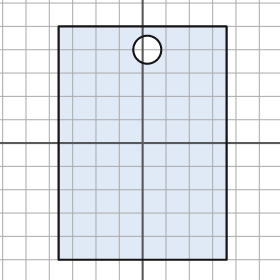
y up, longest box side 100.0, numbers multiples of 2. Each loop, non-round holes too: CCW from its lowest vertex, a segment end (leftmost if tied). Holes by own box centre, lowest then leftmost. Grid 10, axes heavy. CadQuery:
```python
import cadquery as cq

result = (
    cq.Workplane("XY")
    .moveTo(-36.0, -50.0)
    .lineTo(36.0, -50.0)
    .lineTo(36.0, 50.0)
    .lineTo(-36.0, 50.0)
    .close()
    .moveTo(2.0, 40.0)
    .circle(6.0)
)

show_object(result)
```